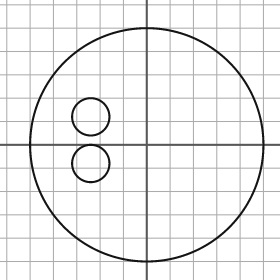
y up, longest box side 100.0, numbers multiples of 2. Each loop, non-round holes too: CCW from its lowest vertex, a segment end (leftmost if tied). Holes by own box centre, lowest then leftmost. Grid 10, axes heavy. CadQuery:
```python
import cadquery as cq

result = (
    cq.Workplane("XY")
    .moveTo(0.0, 0.0)
    .circle(50.0)
    .moveTo(-24.0, -8.0)
    .circle(8.0)
    .moveTo(-24.0, 12.0)
    .circle(8.0)
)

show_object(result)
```